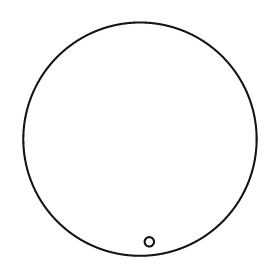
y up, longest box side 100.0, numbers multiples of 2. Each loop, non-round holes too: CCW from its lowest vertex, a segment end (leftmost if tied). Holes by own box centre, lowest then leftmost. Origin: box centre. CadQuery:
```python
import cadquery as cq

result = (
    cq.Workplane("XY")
    .moveTo(0.0, 0.0)
    .circle(50.0)
    .moveTo(4.0, -44.0)
    .circle(2.0)
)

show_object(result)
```